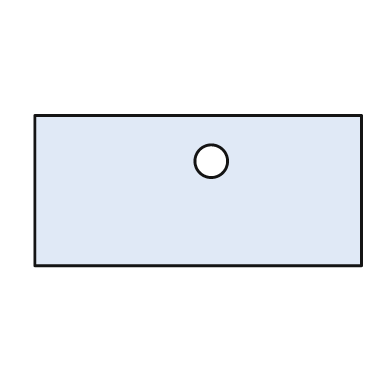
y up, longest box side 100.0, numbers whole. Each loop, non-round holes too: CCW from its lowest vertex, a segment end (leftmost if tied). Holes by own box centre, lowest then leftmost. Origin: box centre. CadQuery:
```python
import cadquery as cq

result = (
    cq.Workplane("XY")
    .moveTo(-50.0, -23.0)
    .lineTo(50.0, -23.0)
    .lineTo(50.0, 23.0)
    .lineTo(-50.0, 23.0)
    .close()
    .moveTo(4.0, 9.0)
    .circle(5.0)
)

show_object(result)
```